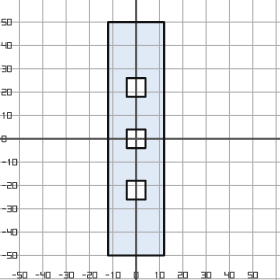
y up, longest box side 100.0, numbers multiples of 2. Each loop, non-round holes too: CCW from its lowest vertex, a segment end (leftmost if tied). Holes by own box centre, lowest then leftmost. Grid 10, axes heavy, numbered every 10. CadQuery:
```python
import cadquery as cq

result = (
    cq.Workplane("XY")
    .moveTo(-12.0, -50.0)
    .lineTo(12.0, -50.0)
    .lineTo(12.0, 50.0)
    .lineTo(-12.0, 50.0)
    .close()
    .moveTo(-4.0, -26.0)
    .lineTo(4.0, -26.0)
    .lineTo(4.0, -18.0)
    .lineTo(-4.0, -18.0)
    .close()
    .moveTo(-4.0, -4.0)
    .lineTo(4.0, -4.0)
    .lineTo(4.0, 4.0)
    .lineTo(-4.0, 4.0)
    .close()
    .moveTo(-4.0, 18.0)
    .lineTo(4.0, 18.0)
    .lineTo(4.0, 26.0)
    .lineTo(-4.0, 26.0)
    .close()
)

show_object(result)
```